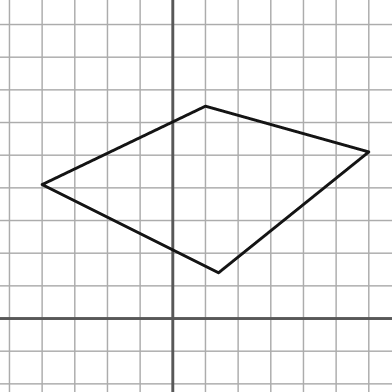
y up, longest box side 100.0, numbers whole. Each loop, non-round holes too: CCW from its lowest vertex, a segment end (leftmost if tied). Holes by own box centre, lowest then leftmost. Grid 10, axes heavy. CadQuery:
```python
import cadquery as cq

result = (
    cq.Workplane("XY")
    .moveTo(14.0, 14.0)
    .lineTo(60.0, 51.0)
    .lineTo(10.0, 65.0)
    .lineTo(-40.0, 41.0)
    .close()
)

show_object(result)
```